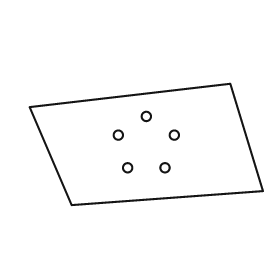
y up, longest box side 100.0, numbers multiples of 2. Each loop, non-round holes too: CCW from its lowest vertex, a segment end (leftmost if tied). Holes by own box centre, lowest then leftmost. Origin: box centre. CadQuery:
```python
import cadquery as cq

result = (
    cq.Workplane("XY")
    .moveTo(-32.0, -26.0)
    .lineTo(50.0, -20.0)
    .lineTo(36.0, 26.0)
    .lineTo(-50.0, 16.0)
    .close()
    .moveTo(-8.0, -10.0)
    .circle(2.0)
    .moveTo(8.0, -10.0)
    .circle(2.0)
    .moveTo(-12.0, 4.0)
    .circle(2.0)
    .moveTo(12.0, 4.0)
    .circle(2.0)
    .moveTo(0.0, 12.0)
    .circle(2.0)
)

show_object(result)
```